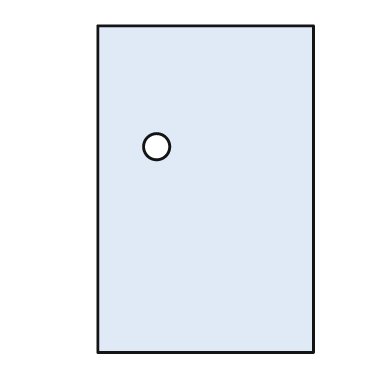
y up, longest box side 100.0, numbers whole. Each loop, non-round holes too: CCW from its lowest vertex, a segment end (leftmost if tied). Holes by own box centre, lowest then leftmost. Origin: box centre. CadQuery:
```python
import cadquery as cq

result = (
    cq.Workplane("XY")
    .moveTo(-33.0, -50.0)
    .lineTo(33.0, -50.0)
    .lineTo(33.0, 50.0)
    .lineTo(-33.0, 50.0)
    .close()
    .moveTo(-15.0, 13.0)
    .circle(4.0)
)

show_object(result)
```